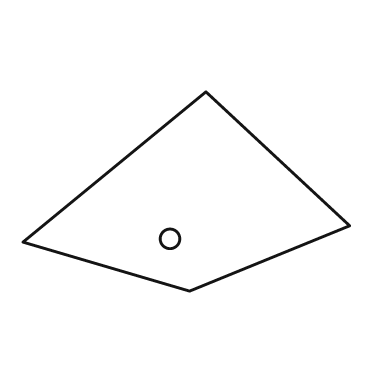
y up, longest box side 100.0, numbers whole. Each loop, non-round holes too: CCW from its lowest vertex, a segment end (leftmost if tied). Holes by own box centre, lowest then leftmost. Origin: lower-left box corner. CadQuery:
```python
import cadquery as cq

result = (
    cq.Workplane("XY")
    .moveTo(51.0, 0.0)
    .lineTo(100.0, 20.0)
    .lineTo(56.0, 61.0)
    .lineTo(0.0, 15.0)
    .close()
    .moveTo(45.0, 16.0)
    .circle(3.0)
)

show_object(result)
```